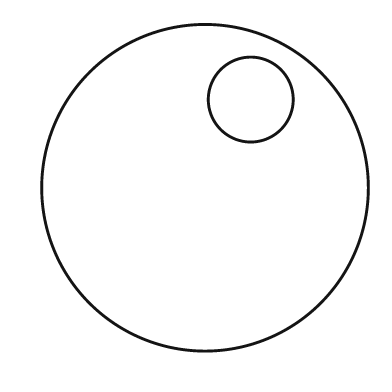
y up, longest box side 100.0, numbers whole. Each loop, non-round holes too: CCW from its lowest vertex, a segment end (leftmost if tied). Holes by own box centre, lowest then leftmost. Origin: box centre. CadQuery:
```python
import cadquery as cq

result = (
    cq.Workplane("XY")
    .moveTo(0.0, 0.0)
    .circle(50.0)
    .moveTo(14.0, 27.0)
    .circle(13.0)
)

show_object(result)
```